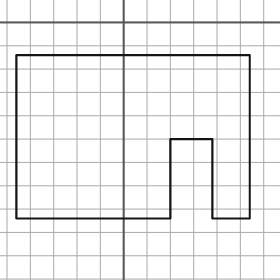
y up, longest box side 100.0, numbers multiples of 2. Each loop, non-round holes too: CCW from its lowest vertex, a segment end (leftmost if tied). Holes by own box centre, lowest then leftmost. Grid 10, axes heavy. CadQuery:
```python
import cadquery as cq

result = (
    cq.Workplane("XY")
    .moveTo(-46.0, -84.0)
    .lineTo(20.0, -84.0)
    .lineTo(20.0, -50.0)
    .lineTo(38.0, -50.0)
    .lineTo(38.0, -84.0)
    .lineTo(54.0, -84.0)
    .lineTo(54.0, -14.0)
    .lineTo(-46.0, -14.0)
    .close()
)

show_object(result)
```